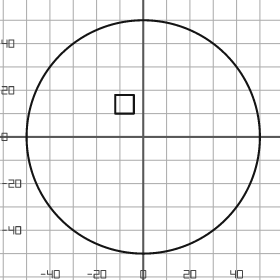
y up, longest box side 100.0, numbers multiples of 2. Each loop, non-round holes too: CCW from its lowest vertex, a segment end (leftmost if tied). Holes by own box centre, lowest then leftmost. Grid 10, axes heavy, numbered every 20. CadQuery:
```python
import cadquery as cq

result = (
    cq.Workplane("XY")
    .moveTo(0.0, 0.0)
    .circle(50.0)
    .moveTo(-12.0, 10.0)
    .lineTo(-4.0, 10.0)
    .lineTo(-4.0, 18.0)
    .lineTo(-12.0, 18.0)
    .close()
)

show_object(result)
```